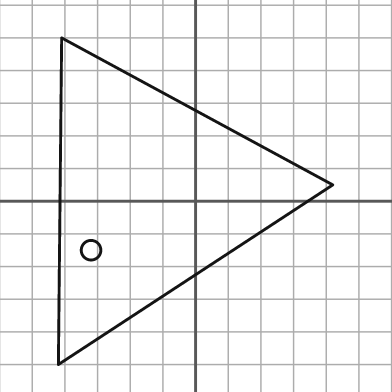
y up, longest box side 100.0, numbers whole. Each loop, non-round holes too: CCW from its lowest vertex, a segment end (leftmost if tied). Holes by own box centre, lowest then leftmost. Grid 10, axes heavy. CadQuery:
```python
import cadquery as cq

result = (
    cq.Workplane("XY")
    .moveTo(-42.0, -50.0)
    .lineTo(42.0, 5.0)
    .lineTo(-41.0, 50.0)
    .close()
    .moveTo(-32.0, -15.0)
    .circle(3.0)
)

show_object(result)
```